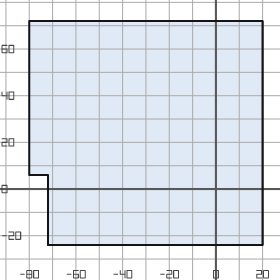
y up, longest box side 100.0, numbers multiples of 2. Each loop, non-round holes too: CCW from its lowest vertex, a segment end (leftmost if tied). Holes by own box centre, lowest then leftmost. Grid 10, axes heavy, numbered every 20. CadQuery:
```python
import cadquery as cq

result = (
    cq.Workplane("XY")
    .moveTo(-72.0, -24.0)
    .lineTo(20.0, -24.0)
    .lineTo(20.0, 72.0)
    .lineTo(-80.0, 72.0)
    .lineTo(-80.0, 6.0)
    .lineTo(-72.0, 6.0)
    .close()
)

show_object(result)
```